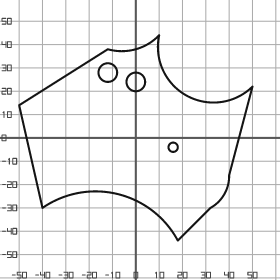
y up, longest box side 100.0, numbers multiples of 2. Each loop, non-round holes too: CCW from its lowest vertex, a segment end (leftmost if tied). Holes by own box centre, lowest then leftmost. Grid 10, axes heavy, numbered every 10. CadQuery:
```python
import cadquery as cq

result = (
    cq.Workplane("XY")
    .moveTo(18.0, -44.0)
    .lineTo(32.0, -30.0)
    .threePointArc((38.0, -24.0), (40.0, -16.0))
    .lineTo(50.0, 22.0)
    .threePointArc((22.0, 18.0), (10.0, 44.0))
    .threePointArc((0.0, 38.0), (-12.0, 38.0))
    .lineTo(-50.0, 14.0)
    .lineTo(-40.0, -30.0)
    .threePointArc((-8.0, -24.0), (18.0, -44.0))
    .close()
    .moveTo(16.0, -4.0)
    .circle(2.0)
    .moveTo(0.0, 24.0)
    .circle(4.0)
    .moveTo(-12.0, 28.0)
    .circle(4.0)
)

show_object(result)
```